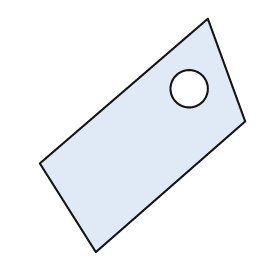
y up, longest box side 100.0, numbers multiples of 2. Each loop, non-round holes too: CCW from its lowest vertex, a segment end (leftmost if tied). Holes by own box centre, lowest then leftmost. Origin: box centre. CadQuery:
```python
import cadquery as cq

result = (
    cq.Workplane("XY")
    .moveTo(-20.0, -50.0)
    .lineTo(44.0, 6.0)
    .lineTo(28.0, 50.0)
    .lineTo(-44.0, -12.0)
    .close()
    .moveTo(20.0, 20.0)
    .circle(8.0)
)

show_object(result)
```